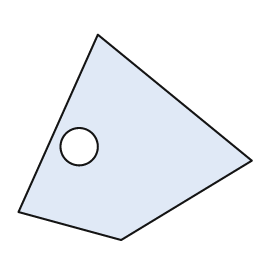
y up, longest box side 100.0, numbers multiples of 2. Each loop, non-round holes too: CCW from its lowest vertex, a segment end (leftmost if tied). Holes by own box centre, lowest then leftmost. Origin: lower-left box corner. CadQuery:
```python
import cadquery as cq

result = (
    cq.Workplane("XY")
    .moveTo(44.0, 0.0)
    .lineTo(100.0, 34.0)
    .lineTo(34.0, 88.0)
    .lineTo(0.0, 12.0)
    .close()
    .moveTo(26.0, 40.0)
    .circle(8.0)
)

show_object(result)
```